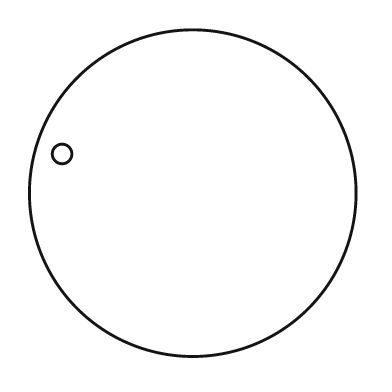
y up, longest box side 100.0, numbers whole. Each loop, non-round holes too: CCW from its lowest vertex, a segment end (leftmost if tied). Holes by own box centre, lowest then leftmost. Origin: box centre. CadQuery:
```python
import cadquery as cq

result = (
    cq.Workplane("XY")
    .moveTo(0.0, 0.0)
    .circle(50.0)
    .moveTo(-40.0, 12.0)
    .circle(3.0)
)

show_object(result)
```